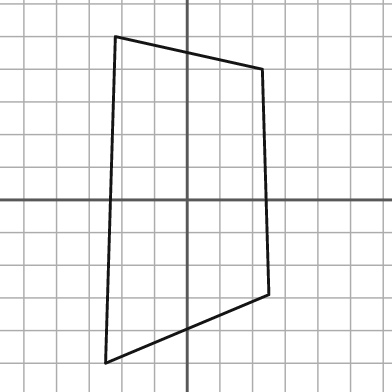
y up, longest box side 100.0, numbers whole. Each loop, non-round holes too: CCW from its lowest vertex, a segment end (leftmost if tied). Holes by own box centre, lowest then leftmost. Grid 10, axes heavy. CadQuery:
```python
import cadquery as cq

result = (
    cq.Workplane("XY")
    .moveTo(-25.0, -50.0)
    .lineTo(25.0, -29.0)
    .lineTo(23.0, 40.0)
    .lineTo(-22.0, 50.0)
    .close()
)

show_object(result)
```